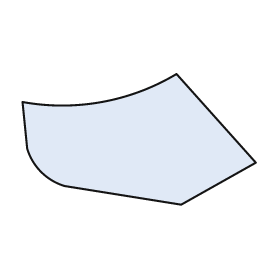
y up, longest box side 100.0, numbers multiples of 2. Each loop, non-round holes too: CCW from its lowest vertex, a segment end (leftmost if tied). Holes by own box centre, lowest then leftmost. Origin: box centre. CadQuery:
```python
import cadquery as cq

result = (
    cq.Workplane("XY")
    .moveTo(18.0, -28.0)
    .lineTo(50.0, -10.0)
    .lineTo(16.0, 28.0)
    .threePointArc((-16.0, 16.0), (-50.0, 16.0))
    .lineTo(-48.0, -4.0)
    .threePointArc((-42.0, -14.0), (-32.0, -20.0))
    .close()
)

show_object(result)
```